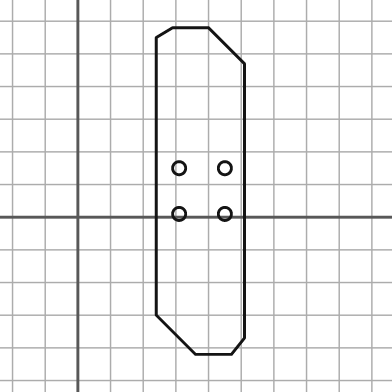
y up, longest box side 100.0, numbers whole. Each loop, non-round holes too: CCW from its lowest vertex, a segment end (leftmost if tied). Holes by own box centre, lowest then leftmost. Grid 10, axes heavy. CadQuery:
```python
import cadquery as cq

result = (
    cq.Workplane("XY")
    .moveTo(36.0, -42.0)
    .lineTo(47.0, -42.0)
    .lineTo(51.0, -37.0)
    .lineTo(51.0, 47.0)
    .lineTo(40.0, 58.0)
    .lineTo(29.0, 58.0)
    .lineTo(24.0, 55.0)
    .lineTo(24.0, -30.0)
    .close()
    .moveTo(31.0, 1.0)
    .circle(2.0)
    .moveTo(45.0, 1.0)
    .circle(2.0)
    .moveTo(31.0, 15.0)
    .circle(2.0)
    .moveTo(45.0, 15.0)
    .circle(2.0)
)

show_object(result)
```